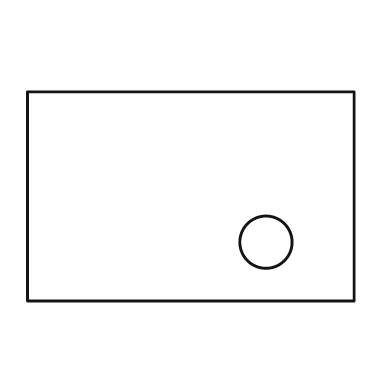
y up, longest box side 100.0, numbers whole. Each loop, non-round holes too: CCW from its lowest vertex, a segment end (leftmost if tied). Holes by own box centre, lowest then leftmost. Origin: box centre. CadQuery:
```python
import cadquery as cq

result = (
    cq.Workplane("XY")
    .moveTo(-50.0, -32.0)
    .lineTo(50.0, -32.0)
    .lineTo(50.0, 32.0)
    .lineTo(-50.0, 32.0)
    .close()
    .moveTo(23.0, -14.0)
    .circle(8.0)
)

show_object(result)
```